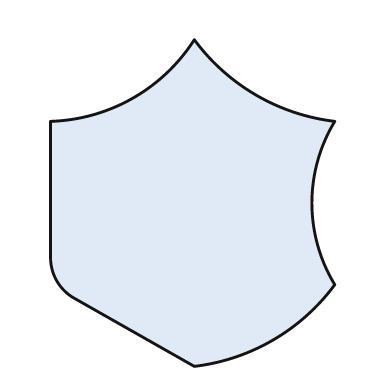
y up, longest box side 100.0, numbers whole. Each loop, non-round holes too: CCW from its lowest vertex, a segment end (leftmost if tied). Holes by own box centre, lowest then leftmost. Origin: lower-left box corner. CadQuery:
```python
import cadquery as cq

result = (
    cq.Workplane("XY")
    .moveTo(44.0, 0.0)
    .threePointArc((68.0, 8.0), (87.0, 25.0))
    .threePointArc((80.0, 50.0), (87.0, 75.0))
    .threePointArc((63.0, 83.0), (44.0, 100.0))
    .threePointArc((25.0, 82.0), (0.0, 75.0))
    .lineTo(0.0, 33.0)
    .threePointArc((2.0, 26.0), (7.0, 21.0))
    .close()
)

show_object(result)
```